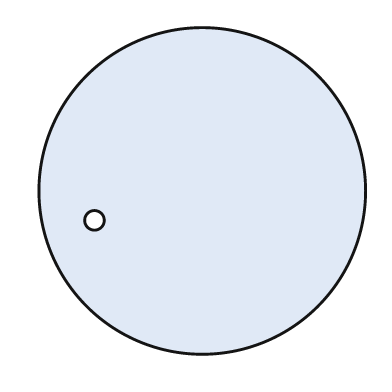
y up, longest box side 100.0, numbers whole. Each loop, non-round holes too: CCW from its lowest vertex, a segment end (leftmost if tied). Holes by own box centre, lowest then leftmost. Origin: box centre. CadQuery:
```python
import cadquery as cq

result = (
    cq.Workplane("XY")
    .moveTo(0.0, 0.0)
    .circle(50.0)
    .moveTo(-33.0, -9.0)
    .circle(3.0)
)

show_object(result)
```